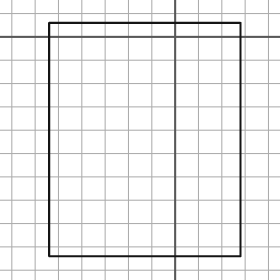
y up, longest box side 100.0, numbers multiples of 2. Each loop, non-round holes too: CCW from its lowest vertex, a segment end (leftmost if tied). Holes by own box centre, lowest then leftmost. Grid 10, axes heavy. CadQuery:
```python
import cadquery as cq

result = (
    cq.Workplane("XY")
    .moveTo(-54.0, -94.0)
    .lineTo(28.0, -94.0)
    .lineTo(28.0, 6.0)
    .lineTo(-54.0, 6.0)
    .close()
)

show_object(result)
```